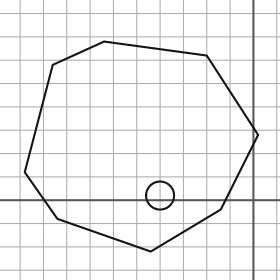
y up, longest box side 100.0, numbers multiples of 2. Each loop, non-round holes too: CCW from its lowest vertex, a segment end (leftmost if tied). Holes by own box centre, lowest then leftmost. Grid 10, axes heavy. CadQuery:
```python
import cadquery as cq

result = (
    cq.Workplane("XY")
    .moveTo(-44.0, -22.0)
    .lineTo(-14.0, -4.0)
    .lineTo(2.0, 28.0)
    .lineTo(-20.0, 62.0)
    .lineTo(-64.0, 68.0)
    .lineTo(-86.0, 58.0)
    .lineTo(-98.0, 12.0)
    .lineTo(-84.0, -8.0)
    .close()
    .moveTo(-40.0, 2.0)
    .circle(6.0)
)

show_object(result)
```